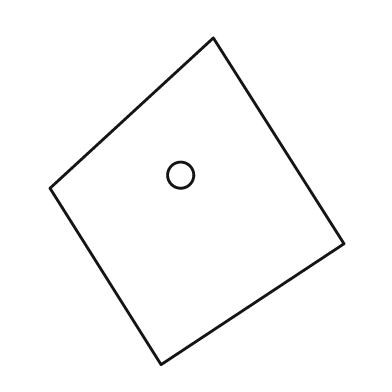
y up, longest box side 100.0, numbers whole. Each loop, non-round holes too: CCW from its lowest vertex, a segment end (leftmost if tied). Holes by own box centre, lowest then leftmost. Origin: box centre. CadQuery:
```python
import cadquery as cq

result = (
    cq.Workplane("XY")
    .moveTo(-11.0, -50.0)
    .lineTo(45.0, -13.0)
    .lineTo(5.0, 50.0)
    .lineTo(-45.0, 4.0)
    .close()
    .moveTo(-5.0, 8.0)
    .circle(4.0)
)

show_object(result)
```